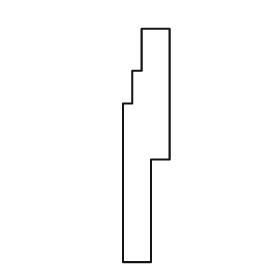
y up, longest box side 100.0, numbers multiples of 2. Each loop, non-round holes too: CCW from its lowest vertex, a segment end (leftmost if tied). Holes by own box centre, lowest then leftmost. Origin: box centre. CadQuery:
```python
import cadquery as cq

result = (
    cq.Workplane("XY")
    .moveTo(-10.0, -50.0)
    .lineTo(2.0, -50.0)
    .lineTo(2.0, -6.0)
    .lineTo(10.0, -6.0)
    .lineTo(10.0, 50.0)
    .lineTo(-2.0, 50.0)
    .lineTo(-2.0, 32.0)
    .lineTo(-6.0, 32.0)
    .lineTo(-6.0, 18.0)
    .lineTo(-10.0, 18.0)
    .close()
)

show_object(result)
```